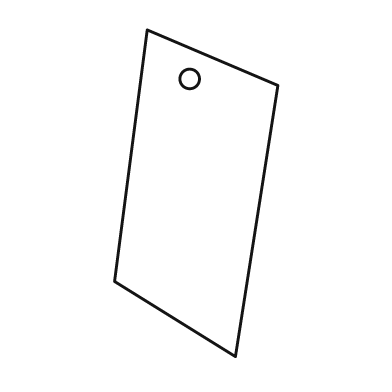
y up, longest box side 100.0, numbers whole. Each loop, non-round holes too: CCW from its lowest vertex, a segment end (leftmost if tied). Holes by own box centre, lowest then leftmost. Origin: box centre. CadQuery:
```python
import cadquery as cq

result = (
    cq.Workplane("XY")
    .moveTo(12.0, -50.0)
    .lineTo(25.0, 33.0)
    .lineTo(-15.0, 50.0)
    .lineTo(-25.0, -27.0)
    .close()
    .moveTo(-2.0, 35.0)
    .circle(3.0)
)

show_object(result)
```